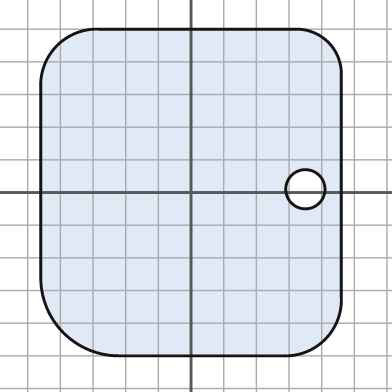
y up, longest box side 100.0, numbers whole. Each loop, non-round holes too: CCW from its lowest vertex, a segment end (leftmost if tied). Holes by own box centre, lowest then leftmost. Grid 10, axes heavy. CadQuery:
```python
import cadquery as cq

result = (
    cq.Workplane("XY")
    .moveTo(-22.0, -50.0)
    .lineTo(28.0, -50.0)
    .threePointArc((41.0, -45.0), (46.0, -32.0))
    .lineTo(46.0, 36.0)
    .threePointArc((42.0, 46.0), (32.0, 50.0))
    .lineTo(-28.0, 50.0)
    .threePointArc((-41.0, 45.0), (-46.0, 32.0))
    .lineTo(-46.0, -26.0)
    .threePointArc((-39.0, -43.0), (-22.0, -50.0))
    .close()
    .moveTo(35.0, 1.0)
    .circle(6.0)
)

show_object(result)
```